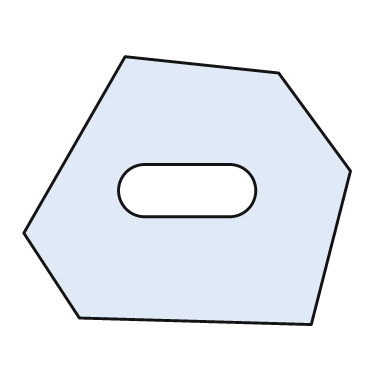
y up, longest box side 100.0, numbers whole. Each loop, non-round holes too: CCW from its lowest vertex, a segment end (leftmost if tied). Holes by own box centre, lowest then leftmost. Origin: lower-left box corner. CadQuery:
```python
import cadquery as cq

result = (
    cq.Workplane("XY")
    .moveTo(88.0, 0.0)
    .lineTo(100.0, 47.0)
    .lineTo(78.0, 77.0)
    .lineTo(31.0, 82.0)
    .lineTo(0.0, 28.0)
    .lineTo(17.0, 2.0)
    .close()
    .moveTo(37.0, 33.0)
    .lineTo(63.0, 33.0)
    .threePointArc((71.0, 41.0), (63.0, 49.0))
    .lineTo(37.0, 49.0)
    .threePointArc((29.0, 41.0), (37.0, 33.0))
    .close()
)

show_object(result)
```